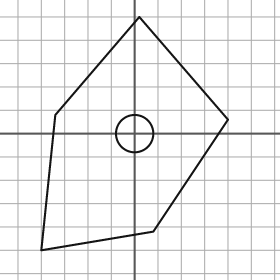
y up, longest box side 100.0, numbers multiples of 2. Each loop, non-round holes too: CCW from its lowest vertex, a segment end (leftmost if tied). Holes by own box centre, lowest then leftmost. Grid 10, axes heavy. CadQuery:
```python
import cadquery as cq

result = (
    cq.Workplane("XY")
    .moveTo(-40.0, -50.0)
    .lineTo(8.0, -42.0)
    .lineTo(40.0, 6.0)
    .lineTo(2.0, 50.0)
    .lineTo(-34.0, 8.0)
    .close()
    .moveTo(0.0, 0.0)
    .circle(8.0)
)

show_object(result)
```